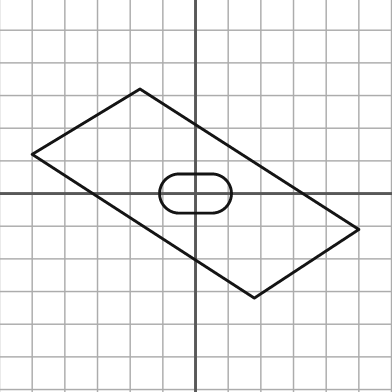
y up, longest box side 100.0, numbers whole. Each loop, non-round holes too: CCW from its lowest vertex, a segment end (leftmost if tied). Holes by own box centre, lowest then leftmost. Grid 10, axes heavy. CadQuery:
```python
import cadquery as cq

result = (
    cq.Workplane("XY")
    .moveTo(18.0, -32.0)
    .lineTo(50.0, -11.0)
    .lineTo(-17.0, 32.0)
    .lineTo(-50.0, 12.0)
    .close()
    .moveTo(-5.0, -6.0)
    .lineTo(5.0, -6.0)
    .threePointArc((11.0, 0.0), (5.0, 6.0))
    .lineTo(-5.0, 6.0)
    .threePointArc((-11.0, 0.0), (-5.0, -6.0))
    .close()
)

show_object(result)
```